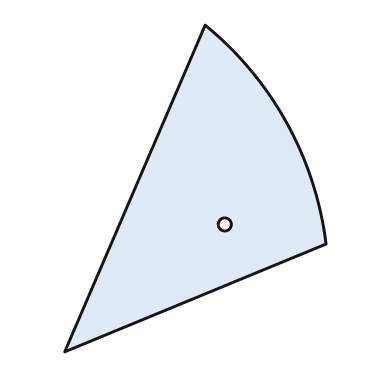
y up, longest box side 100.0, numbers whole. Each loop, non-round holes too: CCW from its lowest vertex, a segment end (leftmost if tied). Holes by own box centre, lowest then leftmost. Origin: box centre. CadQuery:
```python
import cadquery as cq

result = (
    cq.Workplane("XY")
    .moveTo(-40.0, -50.0)
    .lineTo(40.0, -17.0)
    .threePointArc((28.0, 20.0), (3.0, 50.0))
    .close()
    .moveTo(9.0, -11.0)
    .circle(2.0)
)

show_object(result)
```